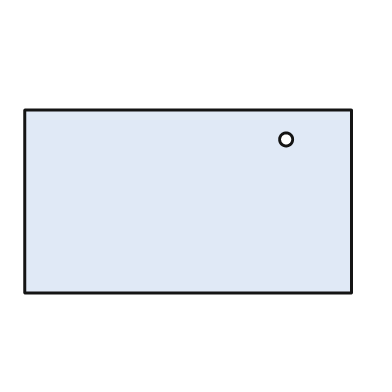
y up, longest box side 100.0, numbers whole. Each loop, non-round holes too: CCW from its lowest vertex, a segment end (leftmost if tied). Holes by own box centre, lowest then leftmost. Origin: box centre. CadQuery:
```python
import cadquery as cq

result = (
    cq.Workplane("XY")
    .moveTo(-50.0, -28.0)
    .lineTo(50.0, -28.0)
    .lineTo(50.0, 28.0)
    .lineTo(-50.0, 28.0)
    .close()
    .moveTo(30.0, 19.0)
    .circle(2.0)
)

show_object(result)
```